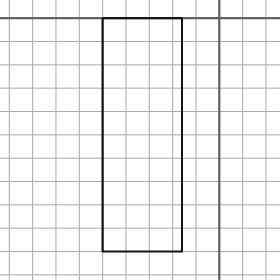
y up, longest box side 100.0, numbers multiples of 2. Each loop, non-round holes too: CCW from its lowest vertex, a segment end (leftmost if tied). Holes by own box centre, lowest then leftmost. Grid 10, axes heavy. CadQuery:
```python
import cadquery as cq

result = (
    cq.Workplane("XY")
    .moveTo(-50.0, -100.0)
    .lineTo(-16.0, -100.0)
    .lineTo(-16.0, 0.0)
    .lineTo(-50.0, 0.0)
    .close()
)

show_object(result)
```